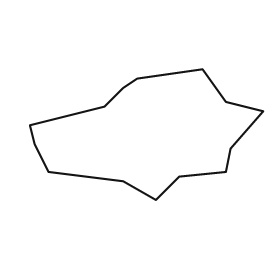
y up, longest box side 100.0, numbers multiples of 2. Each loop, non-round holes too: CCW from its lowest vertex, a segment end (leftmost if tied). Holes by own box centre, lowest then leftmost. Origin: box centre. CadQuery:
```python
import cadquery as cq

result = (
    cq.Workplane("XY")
    .moveTo(4.0, -28.0)
    .lineTo(14.0, -18.0)
    .lineTo(34.0, -16.0)
    .lineTo(36.0, -6.0)
    .lineTo(50.0, 10.0)
    .lineTo(34.0, 14.0)
    .lineTo(24.0, 28.0)
    .lineTo(-4.0, 24.0)
    .lineTo(-10.0, 20.0)
    .lineTo(-18.0, 12.0)
    .lineTo(-50.0, 4.0)
    .lineTo(-48.0, -4.0)
    .lineTo(-42.0, -16.0)
    .lineTo(-10.0, -20.0)
    .close()
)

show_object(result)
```